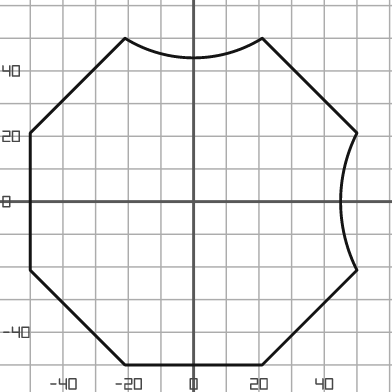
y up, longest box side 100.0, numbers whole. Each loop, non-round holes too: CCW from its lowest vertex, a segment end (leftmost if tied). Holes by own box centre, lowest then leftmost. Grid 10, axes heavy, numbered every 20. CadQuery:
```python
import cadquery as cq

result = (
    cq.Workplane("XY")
    .moveTo(-21.0, -50.0)
    .lineTo(21.0, -50.0)
    .lineTo(50.0, -21.0)
    .threePointArc((45.0, 0.0), (50.0, 21.0))
    .lineTo(21.0, 50.0)
    .threePointArc((0.0, 44.0), (-21.0, 50.0))
    .lineTo(-50.0, 21.0)
    .lineTo(-50.0, -21.0)
    .close()
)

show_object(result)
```